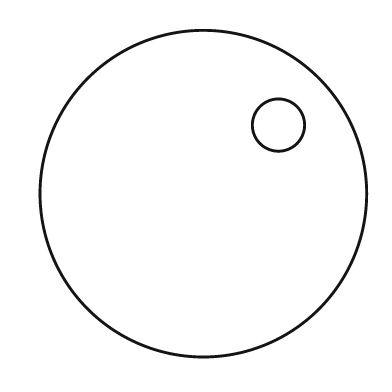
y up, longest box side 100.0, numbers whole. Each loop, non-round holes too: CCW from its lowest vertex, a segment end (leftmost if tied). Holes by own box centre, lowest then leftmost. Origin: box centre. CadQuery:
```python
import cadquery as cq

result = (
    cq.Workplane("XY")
    .moveTo(0.0, 0.0)
    .circle(50.0)
    .moveTo(23.0, 21.0)
    .circle(8.0)
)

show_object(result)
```